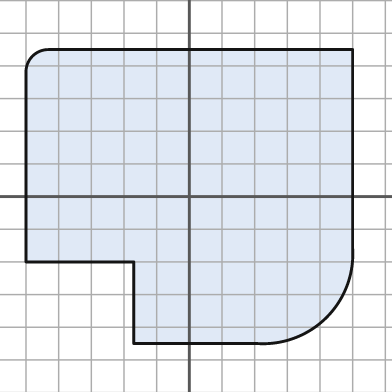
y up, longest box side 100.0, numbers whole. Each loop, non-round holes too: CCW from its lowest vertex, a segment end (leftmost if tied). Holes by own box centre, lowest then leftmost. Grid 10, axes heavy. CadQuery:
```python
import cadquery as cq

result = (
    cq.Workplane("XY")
    .moveTo(-17.0, -45.0)
    .lineTo(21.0, -45.0)
    .threePointArc((42.0, -37.0), (50.0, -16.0))
    .lineTo(50.0, 45.0)
    .lineTo(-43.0, 45.0)
    .threePointArc((-48.0, 43.0), (-50.0, 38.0))
    .lineTo(-50.0, -20.0)
    .lineTo(-17.0, -20.0)
    .close()
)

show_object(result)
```